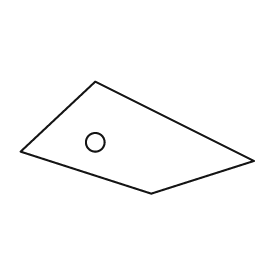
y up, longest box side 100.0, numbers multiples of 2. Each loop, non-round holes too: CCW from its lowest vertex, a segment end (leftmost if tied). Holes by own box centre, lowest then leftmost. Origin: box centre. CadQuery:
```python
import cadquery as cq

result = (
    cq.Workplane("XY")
    .moveTo(6.0, -24.0)
    .lineTo(50.0, -10.0)
    .lineTo(-18.0, 24.0)
    .lineTo(-50.0, -6.0)
    .close()
    .moveTo(-18.0, -2.0)
    .circle(4.0)
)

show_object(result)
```